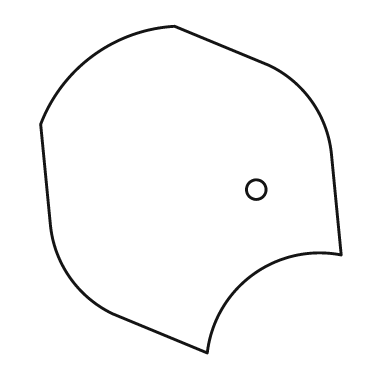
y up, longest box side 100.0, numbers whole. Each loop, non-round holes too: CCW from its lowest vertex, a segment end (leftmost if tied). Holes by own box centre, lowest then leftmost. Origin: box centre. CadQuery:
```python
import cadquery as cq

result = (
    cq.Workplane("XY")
    .moveTo(5.0, -50.0)
    .threePointArc((19.0, -26.0), (46.0, -20.0))
    .lineTo(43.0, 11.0)
    .threePointArc((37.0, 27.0), (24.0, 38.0))
    .lineTo(-5.0, 50.0)
    .threePointArc((-30.0, 41.0), (-46.0, 20.0))
    .lineTo(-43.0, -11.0)
    .threePointArc((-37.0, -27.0), (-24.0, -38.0))
    .close()
    .moveTo(20.0, 0.0)
    .circle(3.0)
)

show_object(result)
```